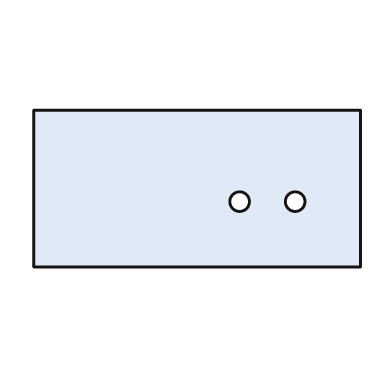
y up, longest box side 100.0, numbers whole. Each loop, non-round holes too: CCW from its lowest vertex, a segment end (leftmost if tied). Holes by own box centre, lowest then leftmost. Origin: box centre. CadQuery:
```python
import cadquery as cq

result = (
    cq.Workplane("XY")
    .moveTo(-50.0, -24.0)
    .lineTo(50.0, -24.0)
    .lineTo(50.0, 24.0)
    .lineTo(-50.0, 24.0)
    .close()
    .moveTo(13.0, -4.0)
    .circle(3.0)
    .moveTo(30.0, -4.0)
    .circle(3.0)
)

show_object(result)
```